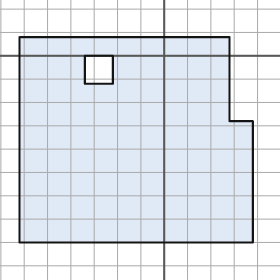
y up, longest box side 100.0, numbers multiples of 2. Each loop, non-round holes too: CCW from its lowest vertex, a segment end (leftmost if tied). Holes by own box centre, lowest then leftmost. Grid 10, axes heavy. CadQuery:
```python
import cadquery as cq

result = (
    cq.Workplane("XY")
    .moveTo(-62.0, -80.0)
    .lineTo(38.0, -80.0)
    .lineTo(38.0, -28.0)
    .lineTo(28.0, -28.0)
    .lineTo(28.0, 8.0)
    .lineTo(-62.0, 8.0)
    .close()
    .moveTo(-34.0, -12.0)
    .lineTo(-22.0, -12.0)
    .lineTo(-22.0, 0.0)
    .lineTo(-34.0, 0.0)
    .close()
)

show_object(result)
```